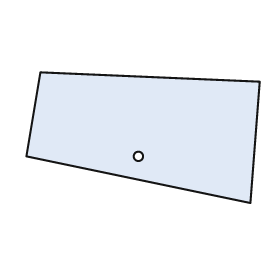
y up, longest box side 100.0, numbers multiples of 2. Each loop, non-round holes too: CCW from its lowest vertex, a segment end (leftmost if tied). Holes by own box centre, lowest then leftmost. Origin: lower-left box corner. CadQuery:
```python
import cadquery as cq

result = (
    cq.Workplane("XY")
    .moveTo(96.0, 0.0)
    .lineTo(100.0, 52.0)
    .lineTo(6.0, 56.0)
    .lineTo(0.0, 20.0)
    .close()
    .moveTo(48.0, 20.0)
    .circle(2.0)
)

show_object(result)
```